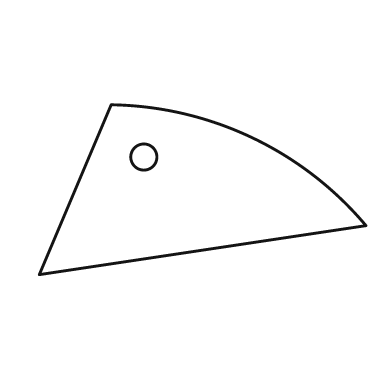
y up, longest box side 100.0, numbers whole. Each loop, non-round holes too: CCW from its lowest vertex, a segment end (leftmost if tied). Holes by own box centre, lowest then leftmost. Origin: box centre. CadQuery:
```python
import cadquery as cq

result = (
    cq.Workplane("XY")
    .moveTo(-50.0, -26.0)
    .lineTo(50.0, -11.0)
    .threePointArc((15.0, 16.0), (-28.0, 26.0))
    .close()
    .moveTo(-18.0, 10.0)
    .circle(4.0)
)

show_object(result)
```